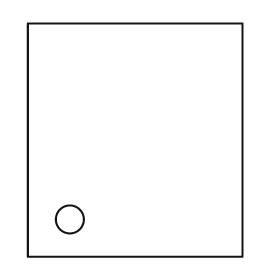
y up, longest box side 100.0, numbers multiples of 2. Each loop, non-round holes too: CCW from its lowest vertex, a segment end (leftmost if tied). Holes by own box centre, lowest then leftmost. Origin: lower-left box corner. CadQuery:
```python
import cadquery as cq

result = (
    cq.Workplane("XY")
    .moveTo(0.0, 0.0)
    .lineTo(92.0, 0.0)
    .lineTo(92.0, 100.0)
    .lineTo(0.0, 100.0)
    .close()
    .moveTo(18.0, 16.0)
    .circle(6.0)
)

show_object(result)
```